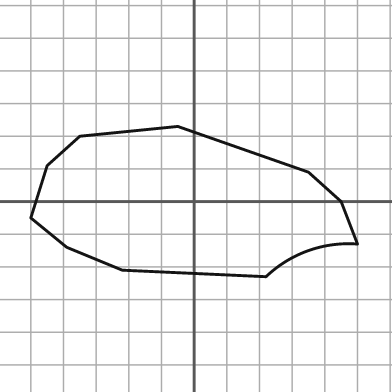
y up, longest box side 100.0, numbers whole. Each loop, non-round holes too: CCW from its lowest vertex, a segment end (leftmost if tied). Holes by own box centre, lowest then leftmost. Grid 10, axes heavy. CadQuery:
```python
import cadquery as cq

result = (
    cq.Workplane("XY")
    .moveTo(22.0, -23.0)
    .threePointArc((35.0, -15.0), (50.0, -13.0))
    .lineTo(45.0, 0.0)
    .lineTo(35.0, 9.0)
    .lineTo(-5.0, 23.0)
    .lineTo(-35.0, 20.0)
    .lineTo(-45.0, 11.0)
    .lineTo(-50.0, -5.0)
    .lineTo(-39.0, -14.0)
    .lineTo(-22.0, -21.0)
    .close()
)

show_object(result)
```